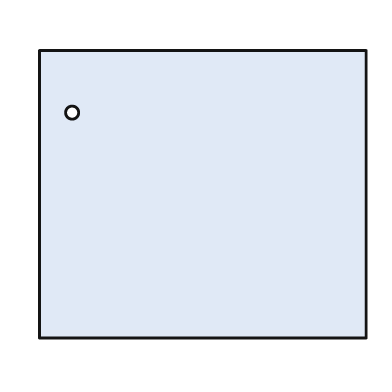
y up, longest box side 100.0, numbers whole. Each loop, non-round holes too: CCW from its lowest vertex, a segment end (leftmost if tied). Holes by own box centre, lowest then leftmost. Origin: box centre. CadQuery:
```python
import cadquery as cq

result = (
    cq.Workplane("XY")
    .moveTo(-50.0, -44.0)
    .lineTo(50.0, -44.0)
    .lineTo(50.0, 44.0)
    .lineTo(-50.0, 44.0)
    .close()
    .moveTo(-40.0, 25.0)
    .circle(2.0)
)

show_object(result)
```